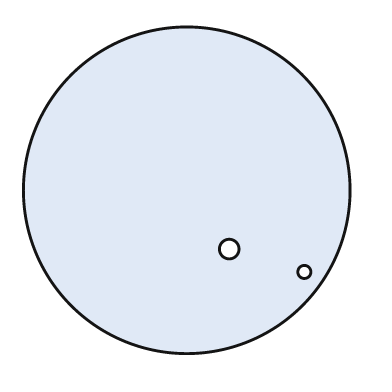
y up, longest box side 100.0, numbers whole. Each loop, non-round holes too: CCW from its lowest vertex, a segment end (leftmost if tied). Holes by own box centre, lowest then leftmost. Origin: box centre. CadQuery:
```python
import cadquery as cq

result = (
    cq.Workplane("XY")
    .moveTo(0.0, 0.0)
    .circle(50.0)
    .moveTo(36.0, -25.0)
    .circle(2.0)
    .moveTo(13.0, -18.0)
    .circle(3.0)
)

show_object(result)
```